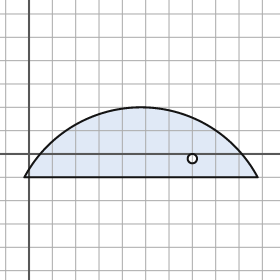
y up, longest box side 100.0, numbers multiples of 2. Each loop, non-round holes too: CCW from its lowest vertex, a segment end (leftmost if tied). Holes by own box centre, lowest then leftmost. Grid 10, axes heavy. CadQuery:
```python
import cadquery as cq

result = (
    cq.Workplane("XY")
    .moveTo(-2.0, -10.0)
    .lineTo(98.0, -10.0)
    .threePointArc((48.0, 20.0), (-2.0, -10.0))
    .close()
    .moveTo(70.0, -2.0)
    .circle(2.0)
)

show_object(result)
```